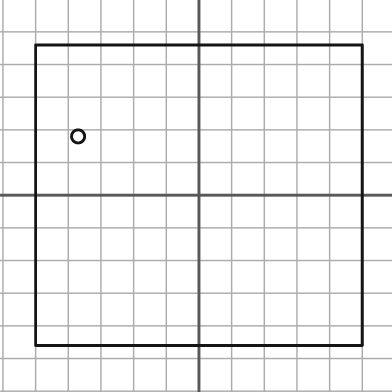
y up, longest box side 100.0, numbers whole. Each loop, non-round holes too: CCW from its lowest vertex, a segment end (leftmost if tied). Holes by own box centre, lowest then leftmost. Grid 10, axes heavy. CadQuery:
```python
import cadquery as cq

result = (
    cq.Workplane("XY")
    .moveTo(-50.0, -46.0)
    .lineTo(50.0, -46.0)
    .lineTo(50.0, 46.0)
    .lineTo(-50.0, 46.0)
    .close()
    .moveTo(-37.0, 18.0)
    .circle(2.0)
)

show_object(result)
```